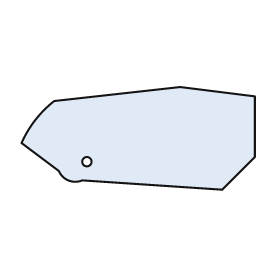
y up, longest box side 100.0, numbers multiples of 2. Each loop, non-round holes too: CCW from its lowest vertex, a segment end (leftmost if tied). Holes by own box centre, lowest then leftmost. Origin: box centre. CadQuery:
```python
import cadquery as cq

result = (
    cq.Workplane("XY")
    .moveTo(36.0, -22.0)
    .lineTo(50.0, -8.0)
    .lineTo(50.0, 18.0)
    .lineTo(18.0, 22.0)
    .lineTo(-36.0, 16.0)
    .threePointArc((-44.0, 8.0), (-50.0, -2.0))
    .lineTo(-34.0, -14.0)
    .threePointArc((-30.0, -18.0), (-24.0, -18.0))
    .close()
    .moveTo(-22.0, -10.0)
    .circle(2.0)
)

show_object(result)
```